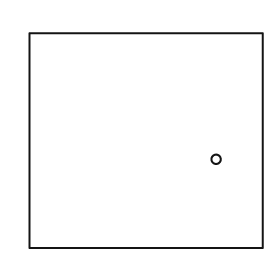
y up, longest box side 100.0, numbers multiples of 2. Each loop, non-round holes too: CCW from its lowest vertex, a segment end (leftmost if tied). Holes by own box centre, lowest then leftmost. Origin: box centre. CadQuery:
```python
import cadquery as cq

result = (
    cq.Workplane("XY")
    .moveTo(-50.0, -46.0)
    .lineTo(50.0, -46.0)
    .lineTo(50.0, 46.0)
    .lineTo(-50.0, 46.0)
    .close()
    .moveTo(30.0, -8.0)
    .circle(2.0)
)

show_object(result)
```